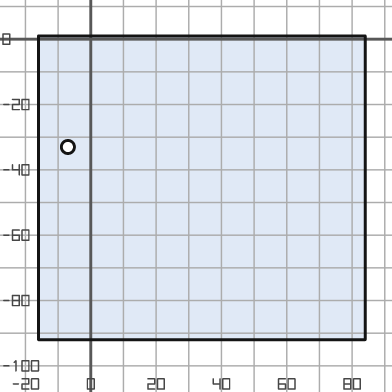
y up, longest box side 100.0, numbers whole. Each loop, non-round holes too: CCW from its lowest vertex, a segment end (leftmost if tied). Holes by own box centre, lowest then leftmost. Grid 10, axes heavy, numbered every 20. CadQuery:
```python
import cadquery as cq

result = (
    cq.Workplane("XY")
    .moveTo(-16.0, -92.0)
    .lineTo(84.0, -92.0)
    .lineTo(84.0, 1.0)
    .lineTo(-16.0, 1.0)
    .close()
    .moveTo(-7.0, -33.0)
    .circle(2.0)
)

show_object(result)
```